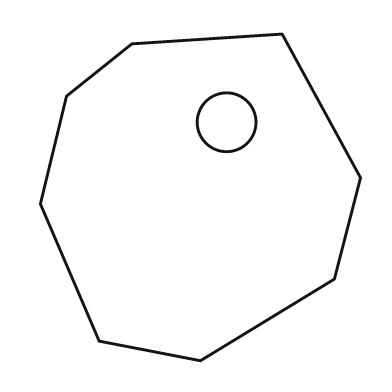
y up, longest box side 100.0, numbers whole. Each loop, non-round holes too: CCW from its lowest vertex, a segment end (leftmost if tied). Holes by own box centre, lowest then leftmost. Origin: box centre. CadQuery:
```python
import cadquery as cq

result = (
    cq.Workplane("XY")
    .moveTo(0.0, -50.0)
    .lineTo(41.0, -25.0)
    .lineTo(49.0, 6.0)
    .lineTo(25.0, 50.0)
    .lineTo(-21.0, 47.0)
    .lineTo(-41.0, 31.0)
    .lineTo(-49.0, -2.0)
    .lineTo(-31.0, -44.0)
    .close()
    .moveTo(8.0, 23.0)
    .circle(9.0)
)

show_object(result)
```